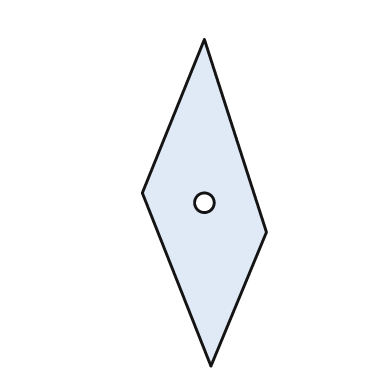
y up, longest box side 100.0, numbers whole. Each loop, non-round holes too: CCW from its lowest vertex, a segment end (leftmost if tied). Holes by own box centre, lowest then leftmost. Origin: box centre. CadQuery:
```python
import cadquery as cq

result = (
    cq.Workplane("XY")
    .moveTo(2.0, -50.0)
    .lineTo(19.0, -9.0)
    .lineTo(0.0, 50.0)
    .lineTo(-19.0, 3.0)
    .close()
    .moveTo(0.0, 0.0)
    .circle(3.0)
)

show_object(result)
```